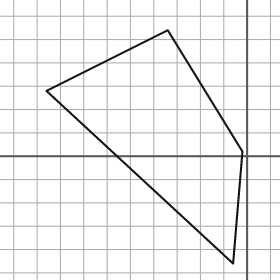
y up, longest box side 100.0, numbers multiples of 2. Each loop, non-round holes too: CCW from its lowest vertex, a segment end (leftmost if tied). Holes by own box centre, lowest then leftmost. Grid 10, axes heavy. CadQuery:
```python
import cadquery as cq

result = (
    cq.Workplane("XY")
    .moveTo(-6.0, -46.0)
    .lineTo(-2.0, 2.0)
    .lineTo(-34.0, 54.0)
    .lineTo(-86.0, 28.0)
    .close()
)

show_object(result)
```